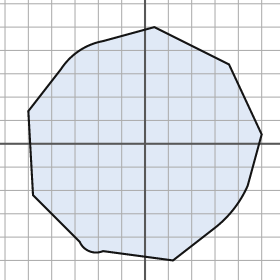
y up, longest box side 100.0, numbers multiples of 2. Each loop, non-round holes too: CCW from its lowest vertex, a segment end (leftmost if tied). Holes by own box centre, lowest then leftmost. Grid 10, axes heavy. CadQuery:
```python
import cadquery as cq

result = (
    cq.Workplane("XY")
    .moveTo(12.0, -50.0)
    .lineTo(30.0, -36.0)
    .threePointArc((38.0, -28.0), (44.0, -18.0))
    .lineTo(50.0, 4.0)
    .lineTo(36.0, 34.0)
    .lineTo(4.0, 50.0)
    .lineTo(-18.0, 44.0)
    .threePointArc((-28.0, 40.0), (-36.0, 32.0))
    .lineTo(-50.0, 14.0)
    .lineTo(-48.0, -22.0)
    .lineTo(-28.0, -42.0)
    .threePointArc((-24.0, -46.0), (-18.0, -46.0))
    .close()
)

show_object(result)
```